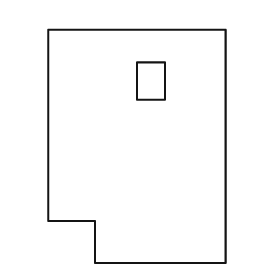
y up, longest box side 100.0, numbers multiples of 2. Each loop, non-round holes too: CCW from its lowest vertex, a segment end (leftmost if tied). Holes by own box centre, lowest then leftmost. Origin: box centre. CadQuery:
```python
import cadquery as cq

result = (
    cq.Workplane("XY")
    .moveTo(-18.0, -50.0)
    .lineTo(38.0, -50.0)
    .lineTo(38.0, 50.0)
    .lineTo(-38.0, 50.0)
    .lineTo(-38.0, -32.0)
    .lineTo(-18.0, -32.0)
    .close()
    .moveTo(0.0, 20.0)
    .lineTo(12.0, 20.0)
    .lineTo(12.0, 36.0)
    .lineTo(0.0, 36.0)
    .close()
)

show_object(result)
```